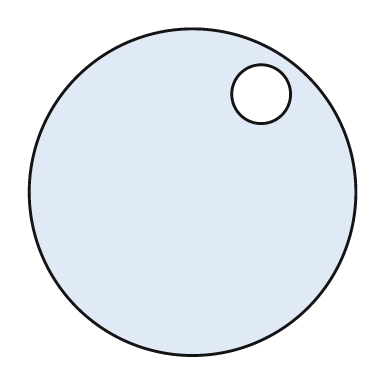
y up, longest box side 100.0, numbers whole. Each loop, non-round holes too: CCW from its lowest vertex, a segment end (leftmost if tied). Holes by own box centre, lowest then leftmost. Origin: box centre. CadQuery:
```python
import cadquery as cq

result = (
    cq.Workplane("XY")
    .moveTo(0.0, 0.0)
    .circle(50.0)
    .moveTo(21.0, 30.0)
    .circle(9.0)
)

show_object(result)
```